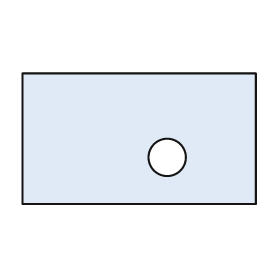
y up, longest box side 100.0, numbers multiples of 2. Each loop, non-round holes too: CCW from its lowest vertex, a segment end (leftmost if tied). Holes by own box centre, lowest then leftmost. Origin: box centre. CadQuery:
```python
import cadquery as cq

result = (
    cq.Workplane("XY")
    .moveTo(-50.0, -28.0)
    .lineTo(50.0, -28.0)
    .lineTo(50.0, 28.0)
    .lineTo(-50.0, 28.0)
    .close()
    .moveTo(12.0, -8.0)
    .circle(8.0)
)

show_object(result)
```